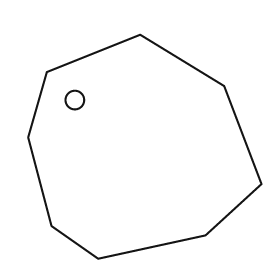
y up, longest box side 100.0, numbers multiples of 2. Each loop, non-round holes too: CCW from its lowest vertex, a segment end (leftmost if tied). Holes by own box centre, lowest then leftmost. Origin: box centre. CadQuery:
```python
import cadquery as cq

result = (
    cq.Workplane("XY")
    .moveTo(-20.0, -48.0)
    .lineTo(26.0, -38.0)
    .lineTo(50.0, -16.0)
    .lineTo(34.0, 26.0)
    .lineTo(-2.0, 48.0)
    .lineTo(-42.0, 32.0)
    .lineTo(-50.0, 4.0)
    .lineTo(-40.0, -34.0)
    .close()
    .moveTo(-30.0, 20.0)
    .circle(4.0)
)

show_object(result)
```